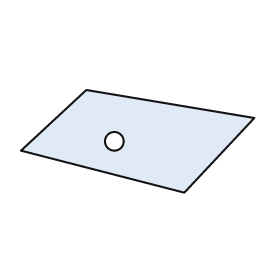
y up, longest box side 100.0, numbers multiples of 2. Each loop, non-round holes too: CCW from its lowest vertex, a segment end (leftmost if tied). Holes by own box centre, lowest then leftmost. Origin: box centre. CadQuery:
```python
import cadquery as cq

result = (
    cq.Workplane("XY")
    .moveTo(20.0, -22.0)
    .lineTo(50.0, 10.0)
    .lineTo(-22.0, 22.0)
    .lineTo(-50.0, -4.0)
    .close()
    .moveTo(-10.0, 0.0)
    .circle(4.0)
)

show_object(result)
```